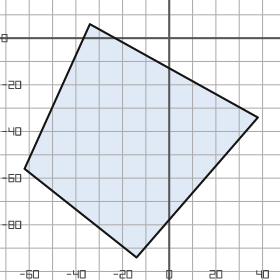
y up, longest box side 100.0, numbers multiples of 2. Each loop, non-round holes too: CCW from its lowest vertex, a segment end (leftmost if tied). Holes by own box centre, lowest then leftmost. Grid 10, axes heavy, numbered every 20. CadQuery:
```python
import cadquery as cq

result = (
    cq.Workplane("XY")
    .moveTo(-14.0, -94.0)
    .lineTo(38.0, -34.0)
    .lineTo(-34.0, 6.0)
    .lineTo(-62.0, -56.0)
    .close()
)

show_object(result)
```